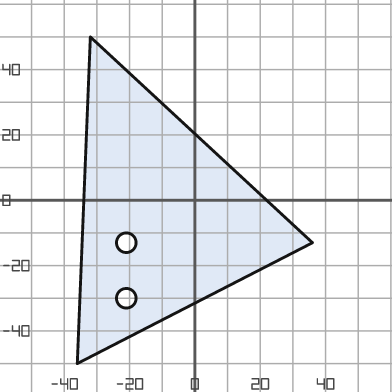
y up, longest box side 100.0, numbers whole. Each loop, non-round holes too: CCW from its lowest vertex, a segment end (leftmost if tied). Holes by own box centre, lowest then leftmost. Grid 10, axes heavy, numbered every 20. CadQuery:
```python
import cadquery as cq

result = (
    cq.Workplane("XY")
    .moveTo(-36.0, -50.0)
    .lineTo(36.0, -13.0)
    .lineTo(-32.0, 50.0)
    .close()
    .moveTo(-21.0, -30.0)
    .circle(3.0)
    .moveTo(-21.0, -13.0)
    .circle(3.0)
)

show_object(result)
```